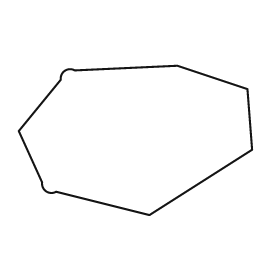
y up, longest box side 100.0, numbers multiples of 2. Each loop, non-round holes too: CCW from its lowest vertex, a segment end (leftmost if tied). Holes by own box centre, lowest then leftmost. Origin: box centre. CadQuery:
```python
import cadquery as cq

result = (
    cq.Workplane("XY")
    .moveTo(6.0, -32.0)
    .lineTo(50.0, -4.0)
    .lineTo(48.0, 22.0)
    .lineTo(18.0, 32.0)
    .lineTo(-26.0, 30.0)
    .threePointArc((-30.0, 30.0), (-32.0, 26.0))
    .lineTo(-50.0, 4.0)
    .lineTo(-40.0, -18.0)
    .threePointArc((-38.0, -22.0), (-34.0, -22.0))
    .close()
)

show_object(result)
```